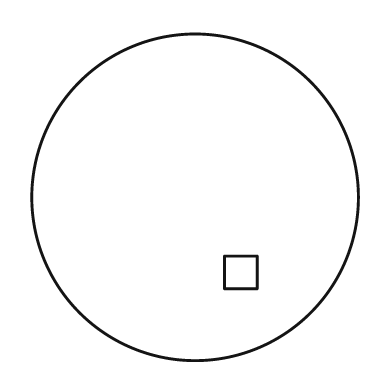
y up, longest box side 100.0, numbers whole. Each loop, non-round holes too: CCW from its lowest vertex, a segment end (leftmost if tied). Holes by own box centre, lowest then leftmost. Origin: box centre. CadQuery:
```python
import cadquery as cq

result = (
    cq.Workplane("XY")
    .moveTo(0.0, 0.0)
    .circle(50.0)
    .moveTo(9.0, -28.0)
    .lineTo(19.0, -28.0)
    .lineTo(19.0, -18.0)
    .lineTo(9.0, -18.0)
    .close()
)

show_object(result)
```